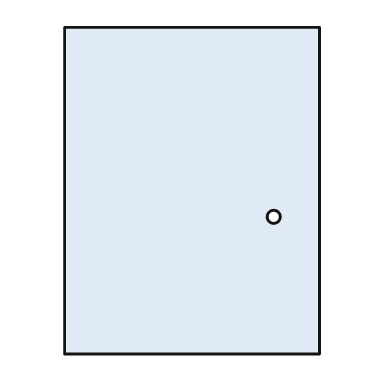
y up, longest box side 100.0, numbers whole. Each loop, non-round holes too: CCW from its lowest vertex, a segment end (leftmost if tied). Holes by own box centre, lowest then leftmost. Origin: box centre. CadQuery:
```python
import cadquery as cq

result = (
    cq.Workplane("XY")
    .moveTo(-39.0, -50.0)
    .lineTo(39.0, -50.0)
    .lineTo(39.0, 50.0)
    .lineTo(-39.0, 50.0)
    .close()
    .moveTo(25.0, -8.0)
    .circle(2.0)
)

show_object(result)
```